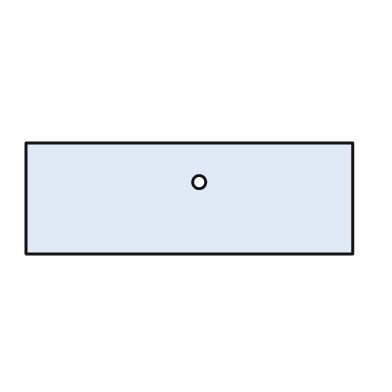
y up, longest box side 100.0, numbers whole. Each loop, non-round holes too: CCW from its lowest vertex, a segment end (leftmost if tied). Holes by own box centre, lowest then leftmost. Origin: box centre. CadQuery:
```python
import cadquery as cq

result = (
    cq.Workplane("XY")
    .moveTo(-50.0, -17.0)
    .lineTo(50.0, -17.0)
    .lineTo(50.0, 17.0)
    .lineTo(-50.0, 17.0)
    .close()
    .moveTo(3.0, 5.0)
    .circle(2.0)
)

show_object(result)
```